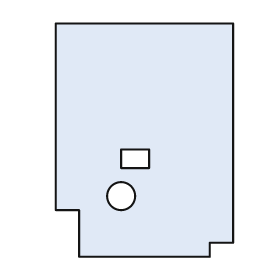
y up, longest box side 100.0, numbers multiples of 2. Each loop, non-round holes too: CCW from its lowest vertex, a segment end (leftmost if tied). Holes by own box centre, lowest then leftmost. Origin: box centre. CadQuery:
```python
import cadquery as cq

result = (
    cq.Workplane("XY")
    .moveTo(-28.0, -50.0)
    .lineTo(28.0, -50.0)
    .lineTo(28.0, -44.0)
    .lineTo(38.0, -44.0)
    .lineTo(38.0, 50.0)
    .lineTo(-38.0, 50.0)
    .lineTo(-38.0, -30.0)
    .lineTo(-28.0, -30.0)
    .close()
    .moveTo(-10.0, -24.0)
    .circle(6.0)
    .moveTo(-10.0, -12.0)
    .lineTo(2.0, -12.0)
    .lineTo(2.0, -4.0)
    .lineTo(-10.0, -4.0)
    .close()
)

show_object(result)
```